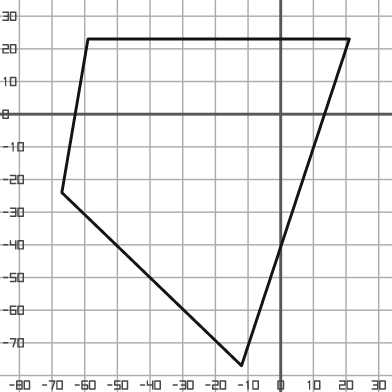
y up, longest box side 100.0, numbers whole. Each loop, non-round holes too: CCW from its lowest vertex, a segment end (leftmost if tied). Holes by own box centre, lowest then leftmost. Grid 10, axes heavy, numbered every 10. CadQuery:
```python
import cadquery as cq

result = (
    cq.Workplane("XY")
    .moveTo(-12.0, -77.0)
    .lineTo(21.0, 23.0)
    .lineTo(-59.0, 23.0)
    .lineTo(-67.0, -24.0)
    .close()
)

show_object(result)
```